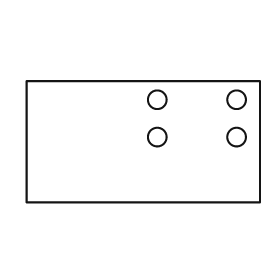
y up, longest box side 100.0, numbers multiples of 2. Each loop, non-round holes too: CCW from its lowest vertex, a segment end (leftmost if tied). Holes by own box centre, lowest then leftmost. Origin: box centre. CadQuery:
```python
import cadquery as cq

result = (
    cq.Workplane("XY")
    .moveTo(-50.0, -26.0)
    .lineTo(50.0, -26.0)
    .lineTo(50.0, 26.0)
    .lineTo(-50.0, 26.0)
    .close()
    .moveTo(6.0, 2.0)
    .circle(4.0)
    .moveTo(40.0, 2.0)
    .circle(4.0)
    .moveTo(6.0, 18.0)
    .circle(4.0)
    .moveTo(40.0, 18.0)
    .circle(4.0)
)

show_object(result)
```